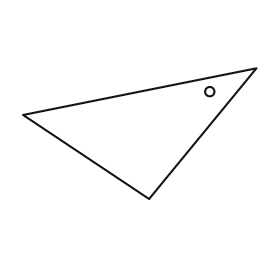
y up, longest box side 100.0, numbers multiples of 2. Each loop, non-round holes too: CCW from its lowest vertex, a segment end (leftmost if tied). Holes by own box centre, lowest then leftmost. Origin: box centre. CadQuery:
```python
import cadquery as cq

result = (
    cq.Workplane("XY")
    .moveTo(4.0, -28.0)
    .lineTo(50.0, 28.0)
    .lineTo(-50.0, 8.0)
    .close()
    .moveTo(30.0, 18.0)
    .circle(2.0)
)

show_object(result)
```